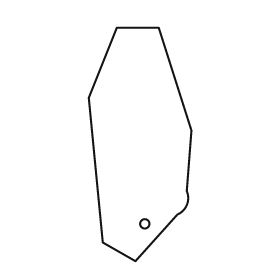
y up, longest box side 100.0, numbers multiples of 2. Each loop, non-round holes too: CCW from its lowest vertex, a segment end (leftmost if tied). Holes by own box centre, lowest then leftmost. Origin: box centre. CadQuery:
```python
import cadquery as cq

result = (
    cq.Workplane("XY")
    .moveTo(-2.0, -50.0)
    .lineTo(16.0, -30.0)
    .threePointArc((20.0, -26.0), (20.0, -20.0))
    .lineTo(22.0, 6.0)
    .lineTo(8.0, 50.0)
    .lineTo(-10.0, 50.0)
    .lineTo(-22.0, 20.0)
    .lineTo(-16.0, -42.0)
    .close()
    .moveTo(2.0, -34.0)
    .circle(2.0)
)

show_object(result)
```